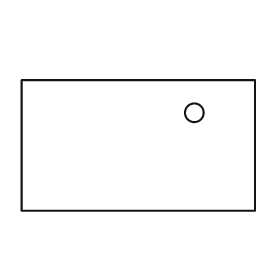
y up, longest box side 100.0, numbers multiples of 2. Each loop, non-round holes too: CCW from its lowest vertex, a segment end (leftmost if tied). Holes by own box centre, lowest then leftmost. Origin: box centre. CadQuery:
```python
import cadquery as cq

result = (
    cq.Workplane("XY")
    .moveTo(-50.0, -28.0)
    .lineTo(50.0, -28.0)
    .lineTo(50.0, 28.0)
    .lineTo(-50.0, 28.0)
    .close()
    .moveTo(24.0, 14.0)
    .circle(4.0)
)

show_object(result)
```